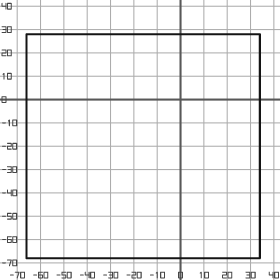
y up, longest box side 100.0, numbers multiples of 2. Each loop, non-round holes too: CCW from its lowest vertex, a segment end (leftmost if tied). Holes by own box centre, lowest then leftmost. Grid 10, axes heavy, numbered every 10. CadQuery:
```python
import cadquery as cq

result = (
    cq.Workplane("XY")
    .moveTo(-66.0, -68.0)
    .lineTo(34.0, -68.0)
    .lineTo(34.0, 28.0)
    .lineTo(-66.0, 28.0)
    .close()
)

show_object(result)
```